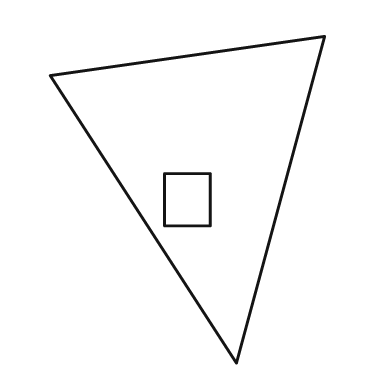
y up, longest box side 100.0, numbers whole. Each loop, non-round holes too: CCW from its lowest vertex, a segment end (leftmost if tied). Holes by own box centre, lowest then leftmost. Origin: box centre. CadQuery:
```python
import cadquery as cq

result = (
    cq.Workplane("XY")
    .moveTo(15.0, -50.0)
    .lineTo(42.0, 50.0)
    .lineTo(-42.0, 38.0)
    .close()
    .moveTo(-7.0, -8.0)
    .lineTo(7.0, -8.0)
    .lineTo(7.0, 8.0)
    .lineTo(-7.0, 8.0)
    .close()
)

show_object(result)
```